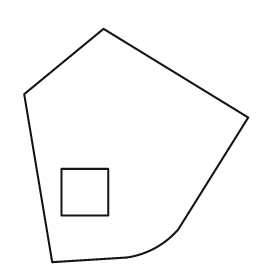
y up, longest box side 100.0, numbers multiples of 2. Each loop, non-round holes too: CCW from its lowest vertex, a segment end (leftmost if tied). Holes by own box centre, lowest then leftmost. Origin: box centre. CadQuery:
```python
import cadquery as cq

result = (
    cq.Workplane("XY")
    .moveTo(-36.0, -50.0)
    .lineTo(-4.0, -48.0)
    .threePointArc((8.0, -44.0), (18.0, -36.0))
    .lineTo(48.0, 12.0)
    .lineTo(-14.0, 50.0)
    .lineTo(-48.0, 22.0)
    .close()
    .moveTo(-32.0, -30.0)
    .lineTo(-12.0, -30.0)
    .lineTo(-12.0, -10.0)
    .lineTo(-32.0, -10.0)
    .close()
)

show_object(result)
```